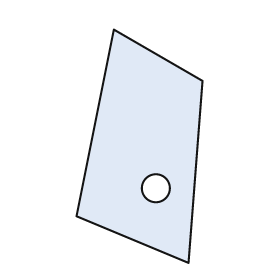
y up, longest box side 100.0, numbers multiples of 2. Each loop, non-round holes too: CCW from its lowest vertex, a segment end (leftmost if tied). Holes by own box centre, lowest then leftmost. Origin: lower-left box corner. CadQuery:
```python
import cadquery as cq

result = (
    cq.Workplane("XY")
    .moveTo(48.0, 0.0)
    .lineTo(54.0, 78.0)
    .lineTo(16.0, 100.0)
    .lineTo(0.0, 20.0)
    .close()
    .moveTo(34.0, 32.0)
    .circle(6.0)
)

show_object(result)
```